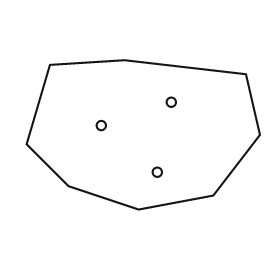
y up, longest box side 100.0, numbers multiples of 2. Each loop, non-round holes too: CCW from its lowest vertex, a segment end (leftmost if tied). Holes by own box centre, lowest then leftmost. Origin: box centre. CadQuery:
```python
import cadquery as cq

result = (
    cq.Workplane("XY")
    .moveTo(-2.0, -32.0)
    .lineTo(30.0, -26.0)
    .lineTo(50.0, 0.0)
    .lineTo(44.0, 26.0)
    .lineTo(-8.0, 32.0)
    .lineTo(-40.0, 30.0)
    .lineTo(-50.0, -4.0)
    .lineTo(-32.0, -22.0)
    .close()
    .moveTo(6.0, -16.0)
    .circle(2.0)
    .moveTo(-18.0, 4.0)
    .circle(2.0)
    .moveTo(12.0, 14.0)
    .circle(2.0)
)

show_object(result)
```